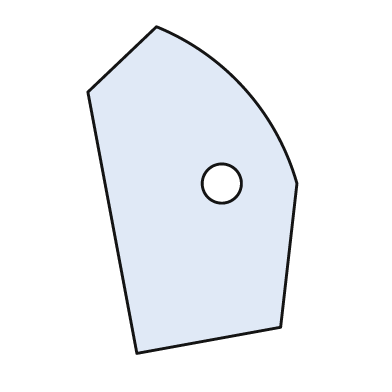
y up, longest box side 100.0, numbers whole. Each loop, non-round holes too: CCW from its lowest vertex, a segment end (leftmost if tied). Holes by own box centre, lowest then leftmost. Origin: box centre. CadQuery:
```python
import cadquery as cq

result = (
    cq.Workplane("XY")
    .moveTo(-17.0, -50.0)
    .lineTo(27.0, -42.0)
    .lineTo(32.0, 2.0)
    .threePointArc((16.0, 31.0), (-11.0, 50.0))
    .lineTo(-32.0, 30.0)
    .close()
    .moveTo(9.0, 2.0)
    .circle(6.0)
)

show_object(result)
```